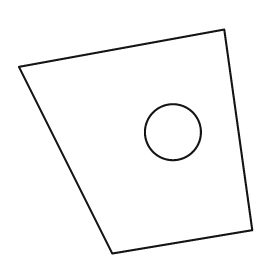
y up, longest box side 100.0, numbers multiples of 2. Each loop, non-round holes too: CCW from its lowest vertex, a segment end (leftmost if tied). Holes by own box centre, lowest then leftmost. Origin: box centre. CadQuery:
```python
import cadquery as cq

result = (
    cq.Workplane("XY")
    .moveTo(-10.0, -48.0)
    .lineTo(50.0, -38.0)
    .lineTo(38.0, 48.0)
    .lineTo(-50.0, 32.0)
    .close()
    .moveTo(16.0, 4.0)
    .circle(12.0)
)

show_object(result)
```